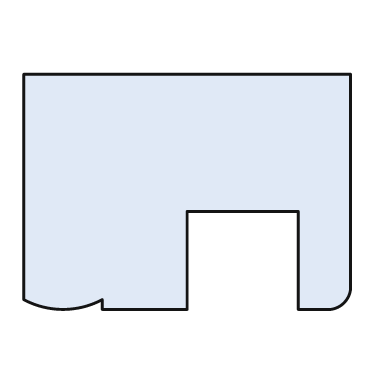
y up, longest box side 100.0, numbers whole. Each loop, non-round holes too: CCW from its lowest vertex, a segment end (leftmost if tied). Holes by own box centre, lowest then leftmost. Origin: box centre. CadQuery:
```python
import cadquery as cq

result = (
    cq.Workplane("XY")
    .moveTo(-26.0, -36.0)
    .lineTo(0.0, -36.0)
    .lineTo(0.0, -6.0)
    .lineTo(34.0, -6.0)
    .lineTo(34.0, -36.0)
    .lineTo(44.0, -36.0)
    .threePointArc((48.0, -34.0), (50.0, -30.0))
    .lineTo(50.0, 36.0)
    .lineTo(-50.0, 36.0)
    .lineTo(-50.0, -33.0)
    .threePointArc((-38.0, -36.0), (-26.0, -33.0))
    .close()
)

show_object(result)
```